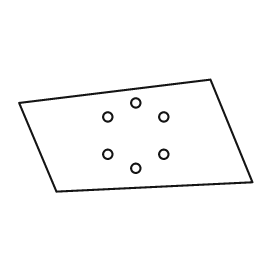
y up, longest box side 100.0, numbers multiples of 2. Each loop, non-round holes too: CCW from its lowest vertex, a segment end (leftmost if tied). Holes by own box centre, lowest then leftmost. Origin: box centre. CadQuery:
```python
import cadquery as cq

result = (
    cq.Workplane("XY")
    .moveTo(-34.0, -24.0)
    .lineTo(50.0, -20.0)
    .lineTo(32.0, 24.0)
    .lineTo(-50.0, 14.0)
    .close()
    .moveTo(0.0, -14.0)
    .circle(2.0)
    .moveTo(-12.0, -8.0)
    .circle(2.0)
    .moveTo(12.0, -8.0)
    .circle(2.0)
    .moveTo(-12.0, 8.0)
    .circle(2.0)
    .moveTo(12.0, 8.0)
    .circle(2.0)
    .moveTo(0.0, 14.0)
    .circle(2.0)
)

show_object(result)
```